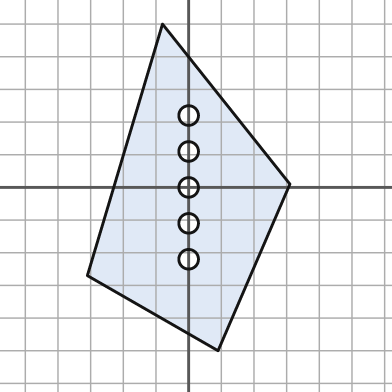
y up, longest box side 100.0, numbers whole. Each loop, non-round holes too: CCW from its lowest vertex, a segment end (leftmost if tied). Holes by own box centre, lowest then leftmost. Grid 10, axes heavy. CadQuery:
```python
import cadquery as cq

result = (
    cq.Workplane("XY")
    .moveTo(9.0, -50.0)
    .lineTo(31.0, 1.0)
    .lineTo(-8.0, 50.0)
    .lineTo(-31.0, -27.0)
    .close()
    .moveTo(0.0, -22.0)
    .circle(3.0)
    .moveTo(0.0, -11.0)
    .circle(3.0)
    .moveTo(0.0, 0.0)
    .circle(3.0)
    .moveTo(0.0, 11.0)
    .circle(3.0)
    .moveTo(0.0, 22.0)
    .circle(3.0)
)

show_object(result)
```